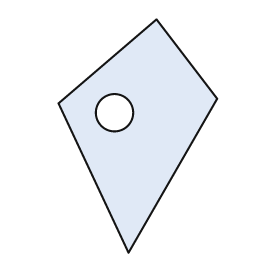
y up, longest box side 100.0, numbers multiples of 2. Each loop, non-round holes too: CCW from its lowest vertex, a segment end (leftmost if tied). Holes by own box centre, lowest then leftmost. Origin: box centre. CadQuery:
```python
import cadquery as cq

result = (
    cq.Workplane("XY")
    .moveTo(-4.0, -50.0)
    .lineTo(34.0, 16.0)
    .lineTo(8.0, 50.0)
    .lineTo(-34.0, 14.0)
    .close()
    .moveTo(-10.0, 10.0)
    .circle(8.0)
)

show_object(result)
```